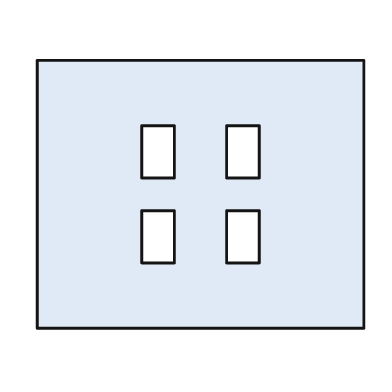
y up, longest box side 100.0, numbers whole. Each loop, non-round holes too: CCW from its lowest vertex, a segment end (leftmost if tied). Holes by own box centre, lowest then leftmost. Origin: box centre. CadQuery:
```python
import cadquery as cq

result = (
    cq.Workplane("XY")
    .moveTo(-50.0, -41.0)
    .lineTo(50.0, -41.0)
    .lineTo(50.0, 41.0)
    .lineTo(-50.0, 41.0)
    .close()
    .moveTo(-18.0, -21.0)
    .lineTo(-8.0, -21.0)
    .lineTo(-8.0, -5.0)
    .lineTo(-18.0, -5.0)
    .close()
    .moveTo(8.0, -21.0)
    .lineTo(18.0, -21.0)
    .lineTo(18.0, -5.0)
    .lineTo(8.0, -5.0)
    .close()
    .moveTo(-18.0, 5.0)
    .lineTo(-8.0, 5.0)
    .lineTo(-8.0, 21.0)
    .lineTo(-18.0, 21.0)
    .close()
    .moveTo(8.0, 5.0)
    .lineTo(18.0, 5.0)
    .lineTo(18.0, 21.0)
    .lineTo(8.0, 21.0)
    .close()
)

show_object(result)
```